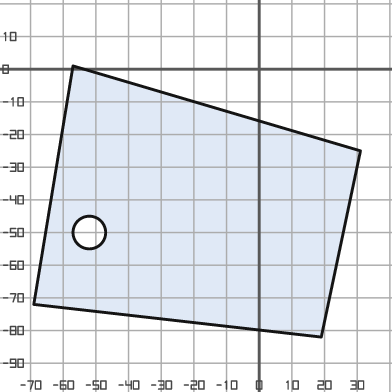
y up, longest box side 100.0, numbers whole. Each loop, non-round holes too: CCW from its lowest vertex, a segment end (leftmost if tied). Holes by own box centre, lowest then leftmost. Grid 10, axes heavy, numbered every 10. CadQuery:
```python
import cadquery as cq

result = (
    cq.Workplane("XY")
    .moveTo(19.0, -82.0)
    .lineTo(31.0, -25.0)
    .lineTo(-57.0, 1.0)
    .lineTo(-69.0, -72.0)
    .close()
    .moveTo(-52.0, -50.0)
    .circle(5.0)
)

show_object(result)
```